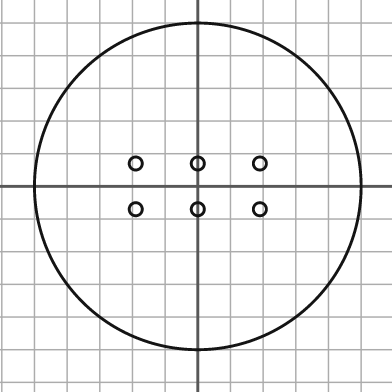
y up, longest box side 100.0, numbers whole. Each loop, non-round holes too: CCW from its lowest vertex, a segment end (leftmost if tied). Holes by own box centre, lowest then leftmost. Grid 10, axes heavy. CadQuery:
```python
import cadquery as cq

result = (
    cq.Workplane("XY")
    .moveTo(0.0, 0.0)
    .circle(50.0)
    .moveTo(-19.0, -7.0)
    .circle(2.0)
    .moveTo(0.0, -7.0)
    .circle(2.0)
    .moveTo(19.0, -7.0)
    .circle(2.0)
    .moveTo(-19.0, 7.0)
    .circle(2.0)
    .moveTo(0.0, 7.0)
    .circle(2.0)
    .moveTo(19.0, 7.0)
    .circle(2.0)
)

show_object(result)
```